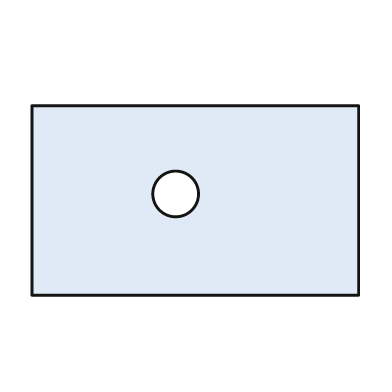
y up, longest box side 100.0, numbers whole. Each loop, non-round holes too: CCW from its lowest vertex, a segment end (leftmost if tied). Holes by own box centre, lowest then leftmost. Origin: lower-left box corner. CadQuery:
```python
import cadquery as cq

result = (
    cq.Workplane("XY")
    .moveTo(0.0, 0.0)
    .lineTo(100.0, 0.0)
    .lineTo(100.0, 58.0)
    .lineTo(0.0, 58.0)
    .close()
    .moveTo(44.0, 31.0)
    .circle(7.0)
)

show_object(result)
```